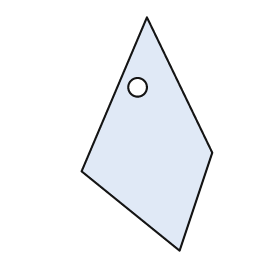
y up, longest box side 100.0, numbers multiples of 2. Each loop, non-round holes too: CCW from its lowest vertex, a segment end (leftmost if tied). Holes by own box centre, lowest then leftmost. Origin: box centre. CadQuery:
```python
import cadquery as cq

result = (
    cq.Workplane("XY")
    .moveTo(14.0, -50.0)
    .lineTo(28.0, -8.0)
    .lineTo(0.0, 50.0)
    .lineTo(-28.0, -16.0)
    .close()
    .moveTo(-4.0, 20.0)
    .circle(4.0)
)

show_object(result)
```